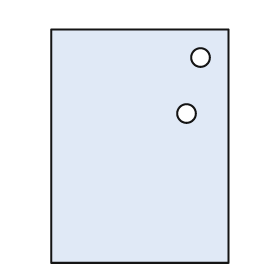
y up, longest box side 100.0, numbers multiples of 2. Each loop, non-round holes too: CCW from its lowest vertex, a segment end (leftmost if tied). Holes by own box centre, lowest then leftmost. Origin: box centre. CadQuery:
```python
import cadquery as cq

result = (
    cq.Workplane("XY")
    .moveTo(-38.0, -50.0)
    .lineTo(38.0, -50.0)
    .lineTo(38.0, 50.0)
    .lineTo(-38.0, 50.0)
    .close()
    .moveTo(20.0, 14.0)
    .circle(4.0)
    .moveTo(26.0, 38.0)
    .circle(4.0)
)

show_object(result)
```